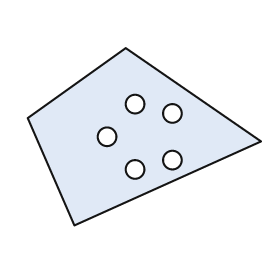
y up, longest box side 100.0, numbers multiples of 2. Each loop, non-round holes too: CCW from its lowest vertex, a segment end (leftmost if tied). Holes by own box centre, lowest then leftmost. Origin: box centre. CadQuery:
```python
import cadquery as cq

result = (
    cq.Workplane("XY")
    .moveTo(-30.0, -38.0)
    .lineTo(50.0, -2.0)
    .lineTo(-8.0, 38.0)
    .lineTo(-50.0, 8.0)
    .close()
    .moveTo(-4.0, -14.0)
    .circle(4.0)
    .moveTo(12.0, -10.0)
    .circle(4.0)
    .moveTo(-16.0, 0.0)
    .circle(4.0)
    .moveTo(12.0, 10.0)
    .circle(4.0)
    .moveTo(-4.0, 14.0)
    .circle(4.0)
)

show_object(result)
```